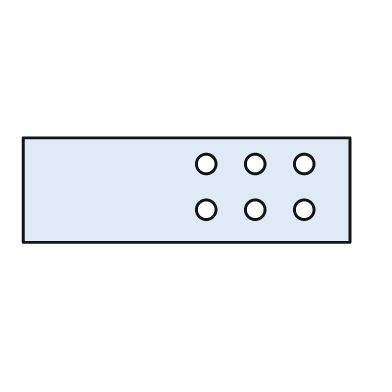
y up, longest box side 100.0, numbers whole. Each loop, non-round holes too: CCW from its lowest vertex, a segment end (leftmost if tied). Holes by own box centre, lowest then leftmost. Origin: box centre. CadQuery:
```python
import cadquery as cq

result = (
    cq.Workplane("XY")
    .moveTo(-50.0, -16.0)
    .lineTo(50.0, -16.0)
    .lineTo(50.0, 16.0)
    .lineTo(-50.0, 16.0)
    .close()
    .moveTo(6.0, -6.0)
    .circle(3.0)
    .moveTo(21.0, -6.0)
    .circle(3.0)
    .moveTo(36.0, -6.0)
    .circle(3.0)
    .moveTo(6.0, 8.0)
    .circle(3.0)
    .moveTo(21.0, 8.0)
    .circle(3.0)
    .moveTo(36.0, 8.0)
    .circle(3.0)
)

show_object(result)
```